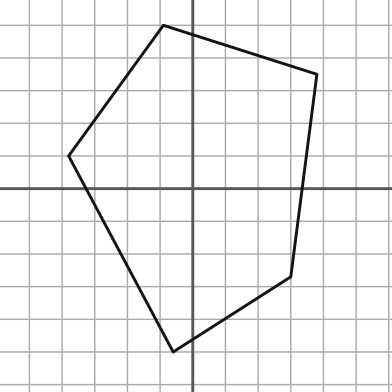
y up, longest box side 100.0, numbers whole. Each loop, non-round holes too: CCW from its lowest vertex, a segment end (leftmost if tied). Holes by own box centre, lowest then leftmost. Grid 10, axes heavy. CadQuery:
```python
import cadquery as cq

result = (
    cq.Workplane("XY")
    .moveTo(-6.0, -50.0)
    .lineTo(30.0, -27.0)
    .lineTo(38.0, 35.0)
    .lineTo(-9.0, 50.0)
    .lineTo(-38.0, 10.0)
    .close()
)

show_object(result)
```